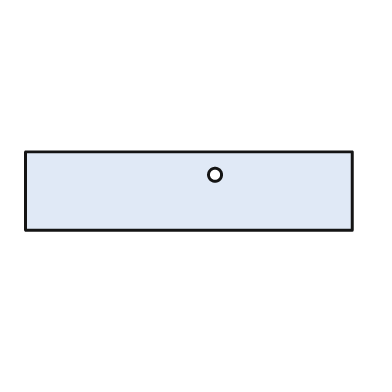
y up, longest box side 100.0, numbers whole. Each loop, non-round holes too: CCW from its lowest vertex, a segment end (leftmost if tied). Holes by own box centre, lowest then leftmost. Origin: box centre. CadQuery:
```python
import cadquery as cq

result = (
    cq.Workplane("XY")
    .moveTo(-50.0, -12.0)
    .lineTo(50.0, -12.0)
    .lineTo(50.0, 12.0)
    .lineTo(-50.0, 12.0)
    .close()
    .moveTo(8.0, 5.0)
    .circle(2.0)
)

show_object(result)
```